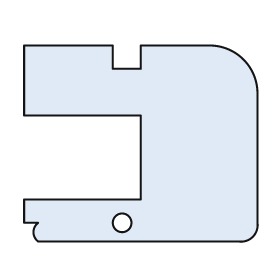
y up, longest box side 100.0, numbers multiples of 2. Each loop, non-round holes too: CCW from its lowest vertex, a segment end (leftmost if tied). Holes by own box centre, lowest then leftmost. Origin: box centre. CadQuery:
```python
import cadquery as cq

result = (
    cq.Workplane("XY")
    .moveTo(-44.0, -42.0)
    .lineTo(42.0, -42.0)
    .threePointArc((48.0, -40.0), (50.0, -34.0))
    .lineTo(50.0, 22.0)
    .threePointArc((44.0, 36.0), (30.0, 42.0))
    .lineTo(0.0, 42.0)
    .lineTo(0.0, 32.0)
    .lineTo(-12.0, 32.0)
    .lineTo(-12.0, 42.0)
    .lineTo(-50.0, 42.0)
    .lineTo(-50.0, 12.0)
    .lineTo(0.0, 12.0)
    .lineTo(0.0, -24.0)
    .lineTo(-50.0, -24.0)
    .lineTo(-50.0, -34.0)
    .lineTo(-44.0, -34.0)
    .threePointArc((-46.0, -38.0), (-44.0, -42.0))
    .close()
    .moveTo(-8.0, -34.0)
    .circle(4.0)
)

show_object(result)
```